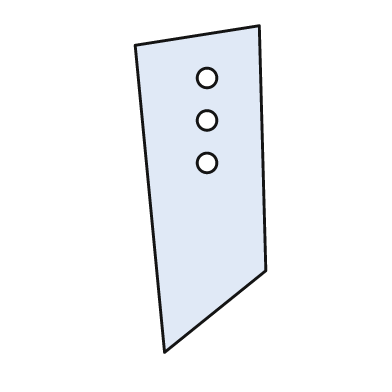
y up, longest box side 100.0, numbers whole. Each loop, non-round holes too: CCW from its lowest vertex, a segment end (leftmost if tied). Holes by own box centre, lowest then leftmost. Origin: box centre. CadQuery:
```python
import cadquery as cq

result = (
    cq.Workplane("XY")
    .moveTo(-11.0, -50.0)
    .lineTo(20.0, -25.0)
    .lineTo(18.0, 50.0)
    .lineTo(-20.0, 44.0)
    .close()
    .moveTo(2.0, 8.0)
    .circle(3.0)
    .moveTo(2.0, 21.0)
    .circle(3.0)
    .moveTo(2.0, 34.0)
    .circle(3.0)
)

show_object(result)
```